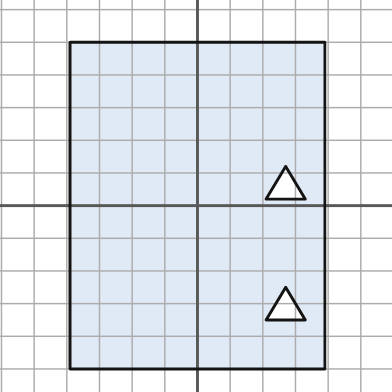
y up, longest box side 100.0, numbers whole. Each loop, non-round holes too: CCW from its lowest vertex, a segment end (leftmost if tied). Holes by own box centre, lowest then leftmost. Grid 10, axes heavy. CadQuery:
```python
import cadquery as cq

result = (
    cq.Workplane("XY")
    .moveTo(-39.0, -50.0)
    .lineTo(39.0, -50.0)
    .lineTo(39.0, 50.0)
    .lineTo(-39.0, 50.0)
    .close()
    .moveTo(21.0, -35.0)
    .lineTo(33.0, -35.0)
    .lineTo(27.0, -25.0)
    .close()
    .moveTo(21.0, 2.0)
    .lineTo(33.0, 2.0)
    .lineTo(27.0, 12.0)
    .close()
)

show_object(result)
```